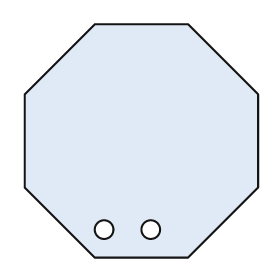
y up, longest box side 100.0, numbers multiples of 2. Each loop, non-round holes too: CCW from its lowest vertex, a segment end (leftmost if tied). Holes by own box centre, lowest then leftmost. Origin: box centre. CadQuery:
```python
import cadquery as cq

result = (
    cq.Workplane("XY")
    .moveTo(-20.0, -50.0)
    .lineTo(20.0, -50.0)
    .lineTo(50.0, -20.0)
    .lineTo(50.0, 20.0)
    .lineTo(20.0, 50.0)
    .lineTo(-20.0, 50.0)
    .lineTo(-50.0, 20.0)
    .lineTo(-50.0, -20.0)
    .close()
    .moveTo(-16.0, -38.0)
    .circle(4.0)
    .moveTo(4.0, -38.0)
    .circle(4.0)
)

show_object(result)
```